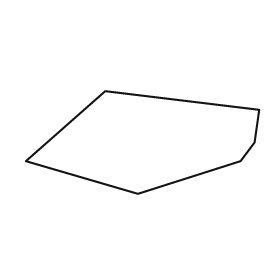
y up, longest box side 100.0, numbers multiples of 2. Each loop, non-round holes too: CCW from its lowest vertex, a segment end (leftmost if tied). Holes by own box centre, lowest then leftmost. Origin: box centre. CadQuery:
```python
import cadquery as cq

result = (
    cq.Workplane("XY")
    .moveTo(-2.0, -22.0)
    .lineTo(42.0, -8.0)
    .lineTo(48.0, 0.0)
    .lineTo(50.0, 14.0)
    .lineTo(-16.0, 22.0)
    .lineTo(-50.0, -8.0)
    .close()
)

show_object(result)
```